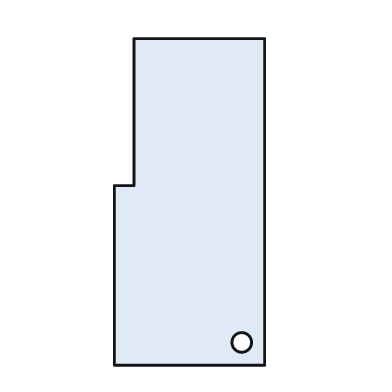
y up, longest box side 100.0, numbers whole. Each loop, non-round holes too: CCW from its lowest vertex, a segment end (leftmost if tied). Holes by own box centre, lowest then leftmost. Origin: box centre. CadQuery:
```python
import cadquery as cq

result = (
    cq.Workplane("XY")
    .moveTo(-23.0, -50.0)
    .lineTo(23.0, -50.0)
    .lineTo(23.0, 50.0)
    .lineTo(-17.0, 50.0)
    .lineTo(-17.0, 5.0)
    .lineTo(-23.0, 5.0)
    .close()
    .moveTo(16.0, -43.0)
    .circle(3.0)
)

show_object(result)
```